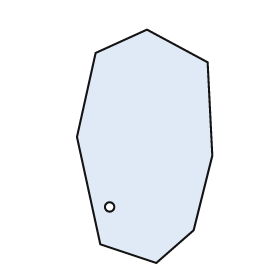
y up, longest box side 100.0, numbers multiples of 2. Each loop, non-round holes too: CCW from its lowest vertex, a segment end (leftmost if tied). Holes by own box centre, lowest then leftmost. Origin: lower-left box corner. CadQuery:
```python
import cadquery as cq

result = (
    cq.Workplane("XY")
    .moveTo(34.0, 0.0)
    .lineTo(50.0, 14.0)
    .lineTo(58.0, 46.0)
    .lineTo(56.0, 86.0)
    .lineTo(30.0, 100.0)
    .lineTo(8.0, 90.0)
    .lineTo(0.0, 54.0)
    .lineTo(10.0, 8.0)
    .close()
    .moveTo(14.0, 24.0)
    .circle(2.0)
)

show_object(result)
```